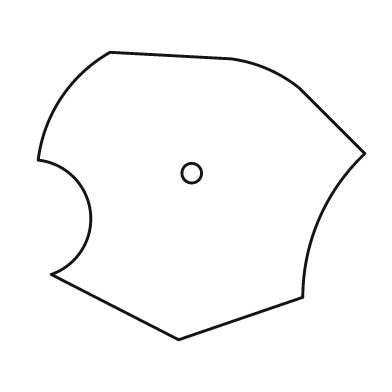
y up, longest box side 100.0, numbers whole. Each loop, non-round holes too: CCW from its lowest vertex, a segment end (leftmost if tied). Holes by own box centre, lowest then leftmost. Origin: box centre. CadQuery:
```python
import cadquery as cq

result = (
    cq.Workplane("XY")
    .moveTo(-7.0, -44.0)
    .lineTo(31.0, -31.0)
    .threePointArc((36.0, -7.0), (50.0, 13.0))
    .lineTo(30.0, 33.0)
    .threePointArc((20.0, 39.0), (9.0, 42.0))
    .lineTo(-28.0, 44.0)
    .threePointArc((-43.0, 30.0), (-50.0, 11.0))
    .threePointArc((-34.0, -5.0), (-46.0, -24.0))
    .close()
    .moveTo(-3.0, 7.0)
    .circle(3.0)
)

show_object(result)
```